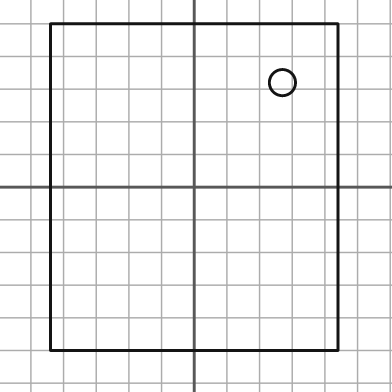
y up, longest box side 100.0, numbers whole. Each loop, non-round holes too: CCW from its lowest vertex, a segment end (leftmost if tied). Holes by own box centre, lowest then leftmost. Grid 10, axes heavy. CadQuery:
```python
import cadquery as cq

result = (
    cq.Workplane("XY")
    .moveTo(-44.0, -50.0)
    .lineTo(44.0, -50.0)
    .lineTo(44.0, 50.0)
    .lineTo(-44.0, 50.0)
    .close()
    .moveTo(27.0, 32.0)
    .circle(4.0)
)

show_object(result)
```